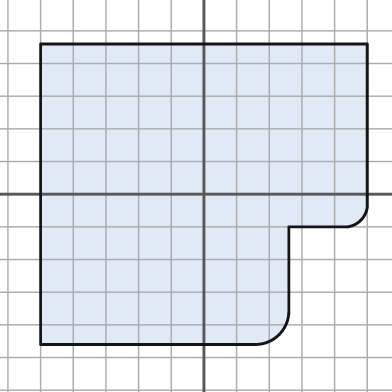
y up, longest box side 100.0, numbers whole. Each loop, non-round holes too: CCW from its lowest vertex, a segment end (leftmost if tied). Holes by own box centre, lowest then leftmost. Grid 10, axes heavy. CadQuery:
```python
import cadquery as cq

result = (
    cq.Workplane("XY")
    .moveTo(-50.0, -46.0)
    .lineTo(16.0, -46.0)
    .threePointArc((23.0, -43.0), (26.0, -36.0))
    .lineTo(26.0, -10.0)
    .lineTo(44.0, -10.0)
    .threePointArc((48.0, -8.0), (50.0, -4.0))
    .lineTo(50.0, 46.0)
    .lineTo(-50.0, 46.0)
    .close()
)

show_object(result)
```